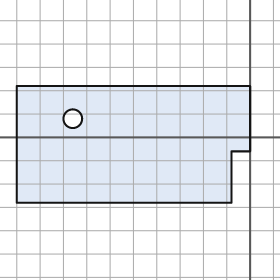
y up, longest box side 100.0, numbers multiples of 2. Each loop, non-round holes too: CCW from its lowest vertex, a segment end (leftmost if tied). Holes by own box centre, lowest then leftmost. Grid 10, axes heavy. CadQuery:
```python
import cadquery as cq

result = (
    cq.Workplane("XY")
    .moveTo(-100.0, -28.0)
    .lineTo(-8.0, -28.0)
    .lineTo(-8.0, -6.0)
    .lineTo(0.0, -6.0)
    .lineTo(0.0, 22.0)
    .lineTo(-100.0, 22.0)
    .close()
    .moveTo(-76.0, 8.0)
    .circle(4.0)
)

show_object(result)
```